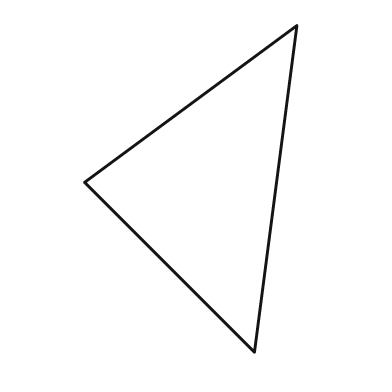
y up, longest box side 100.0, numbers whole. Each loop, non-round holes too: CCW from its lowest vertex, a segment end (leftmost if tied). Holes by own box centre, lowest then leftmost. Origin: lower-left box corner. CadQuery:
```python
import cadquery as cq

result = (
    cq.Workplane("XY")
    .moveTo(52.0, 0.0)
    .lineTo(65.0, 100.0)
    .lineTo(0.0, 52.0)
    .close()
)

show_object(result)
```